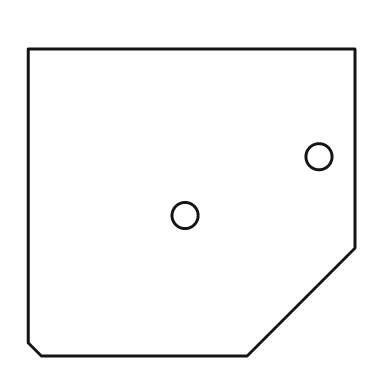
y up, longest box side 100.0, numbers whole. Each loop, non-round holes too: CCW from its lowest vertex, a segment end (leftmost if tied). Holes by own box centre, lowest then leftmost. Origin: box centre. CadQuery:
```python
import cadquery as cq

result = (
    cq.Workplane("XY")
    .moveTo(-46.0, -47.0)
    .lineTo(17.0, -47.0)
    .lineTo(50.0, -14.0)
    .lineTo(50.0, 47.0)
    .lineTo(-50.0, 47.0)
    .lineTo(-50.0, -43.0)
    .close()
    .moveTo(-2.0, -4.0)
    .circle(4.0)
    .moveTo(39.0, 14.0)
    .circle(4.0)
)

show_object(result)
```